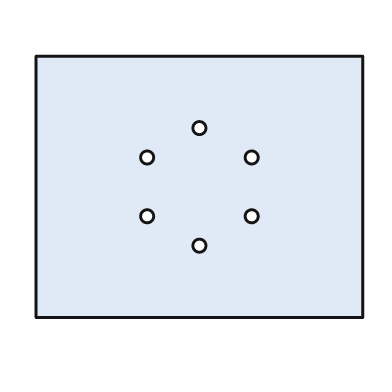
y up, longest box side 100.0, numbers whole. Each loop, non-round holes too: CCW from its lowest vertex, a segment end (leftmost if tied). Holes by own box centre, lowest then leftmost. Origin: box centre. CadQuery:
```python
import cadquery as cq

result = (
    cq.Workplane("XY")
    .moveTo(-50.0, -40.0)
    .lineTo(50.0, -40.0)
    .lineTo(50.0, 40.0)
    .lineTo(-50.0, 40.0)
    .close()
    .moveTo(0.0, -18.0)
    .circle(2.0)
    .moveTo(-16.0, -9.0)
    .circle(2.0)
    .moveTo(16.0, -9.0)
    .circle(2.0)
    .moveTo(-16.0, 9.0)
    .circle(2.0)
    .moveTo(16.0, 9.0)
    .circle(2.0)
    .moveTo(0.0, 18.0)
    .circle(2.0)
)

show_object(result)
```